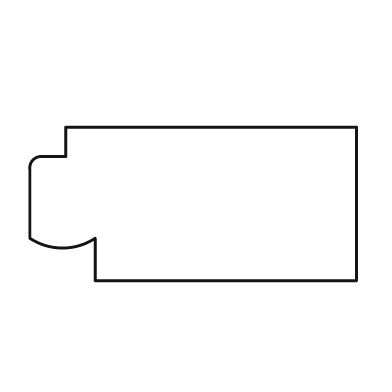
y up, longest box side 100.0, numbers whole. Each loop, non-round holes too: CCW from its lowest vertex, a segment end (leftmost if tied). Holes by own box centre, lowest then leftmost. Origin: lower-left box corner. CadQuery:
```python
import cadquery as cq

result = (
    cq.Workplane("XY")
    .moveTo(20.0, 0.0)
    .lineTo(100.0, 0.0)
    .lineTo(100.0, 47.0)
    .lineTo(11.0, 47.0)
    .lineTo(11.0, 38.0)
    .lineTo(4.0, 38.0)
    .threePointArc((1.0, 37.0), (0.0, 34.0))
    .lineTo(0.0, 13.0)
    .threePointArc((10.0, 10.0), (20.0, 13.0))
    .close()
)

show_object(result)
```